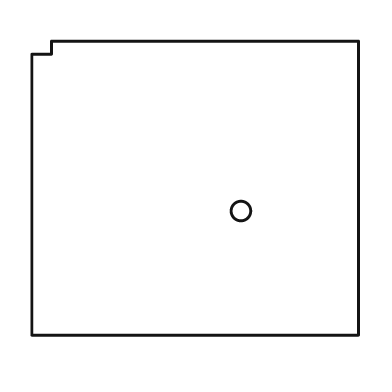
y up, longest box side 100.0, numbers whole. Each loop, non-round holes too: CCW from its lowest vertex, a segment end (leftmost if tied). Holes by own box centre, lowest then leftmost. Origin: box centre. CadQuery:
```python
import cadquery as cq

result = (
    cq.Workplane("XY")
    .moveTo(-50.0, -45.0)
    .lineTo(50.0, -45.0)
    .lineTo(50.0, 45.0)
    .lineTo(-44.0, 45.0)
    .lineTo(-44.0, 41.0)
    .lineTo(-50.0, 41.0)
    .close()
    .moveTo(14.0, -7.0)
    .circle(3.0)
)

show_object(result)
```